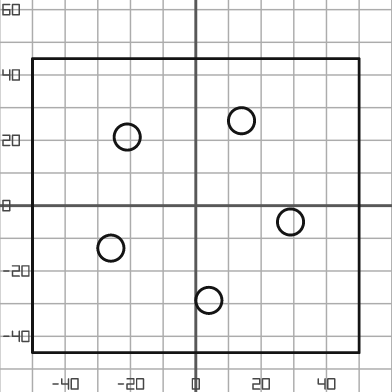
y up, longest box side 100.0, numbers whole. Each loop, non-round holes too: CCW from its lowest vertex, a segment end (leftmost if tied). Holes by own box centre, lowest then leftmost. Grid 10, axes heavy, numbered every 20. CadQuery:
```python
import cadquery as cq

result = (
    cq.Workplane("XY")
    .moveTo(-50.0, -45.0)
    .lineTo(50.0, -45.0)
    .lineTo(50.0, 45.0)
    .lineTo(-50.0, 45.0)
    .close()
    .moveTo(4.0, -29.0)
    .circle(4.0)
    .moveTo(-26.0, -13.0)
    .circle(4.0)
    .moveTo(29.0, -5.0)
    .circle(4.0)
    .moveTo(-21.0, 21.0)
    .circle(4.0)
    .moveTo(14.0, 26.0)
    .circle(4.0)
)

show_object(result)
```